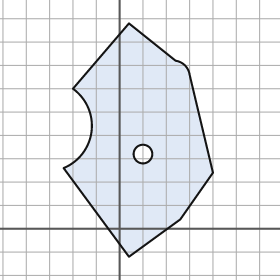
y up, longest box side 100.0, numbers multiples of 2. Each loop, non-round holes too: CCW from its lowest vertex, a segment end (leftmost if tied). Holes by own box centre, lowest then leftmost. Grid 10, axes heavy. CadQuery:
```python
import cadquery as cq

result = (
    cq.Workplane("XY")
    .moveTo(4.0, -12.0)
    .lineTo(26.0, 4.0)
    .lineTo(40.0, 24.0)
    .lineTo(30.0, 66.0)
    .threePointArc((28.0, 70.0), (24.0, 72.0))
    .lineTo(4.0, 88.0)
    .lineTo(-20.0, 60.0)
    .threePointArc((-12.0, 42.0), (-24.0, 26.0))
    .close()
    .moveTo(10.0, 32.0)
    .circle(4.0)
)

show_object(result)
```